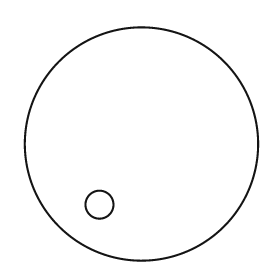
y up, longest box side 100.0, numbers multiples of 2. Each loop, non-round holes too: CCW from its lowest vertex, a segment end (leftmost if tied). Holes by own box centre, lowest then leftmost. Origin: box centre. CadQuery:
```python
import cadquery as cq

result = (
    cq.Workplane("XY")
    .moveTo(0.0, 0.0)
    .circle(50.0)
    .moveTo(-18.0, -26.0)
    .circle(6.0)
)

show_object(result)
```